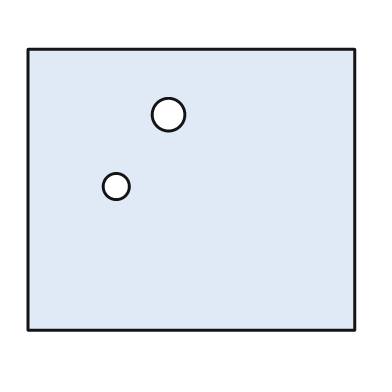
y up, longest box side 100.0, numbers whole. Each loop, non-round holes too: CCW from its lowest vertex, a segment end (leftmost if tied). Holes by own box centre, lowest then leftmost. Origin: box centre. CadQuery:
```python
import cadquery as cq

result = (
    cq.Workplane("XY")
    .moveTo(-50.0, -43.0)
    .lineTo(50.0, -43.0)
    .lineTo(50.0, 43.0)
    .lineTo(-50.0, 43.0)
    .close()
    .moveTo(-23.0, 1.0)
    .circle(4.0)
    .moveTo(-7.0, 23.0)
    .circle(5.0)
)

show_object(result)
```